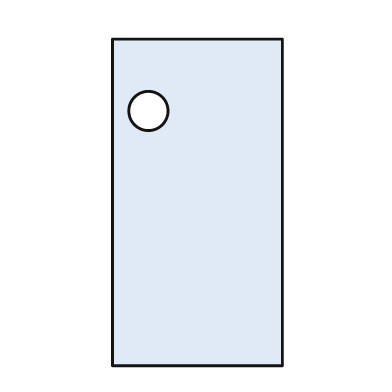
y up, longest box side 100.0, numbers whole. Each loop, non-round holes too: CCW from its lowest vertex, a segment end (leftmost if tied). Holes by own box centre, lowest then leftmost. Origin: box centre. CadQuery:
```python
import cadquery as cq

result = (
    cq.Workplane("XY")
    .moveTo(-26.0, -50.0)
    .lineTo(26.0, -50.0)
    .lineTo(26.0, 50.0)
    .lineTo(-26.0, 50.0)
    .close()
    .moveTo(-15.0, 28.0)
    .circle(6.0)
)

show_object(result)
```